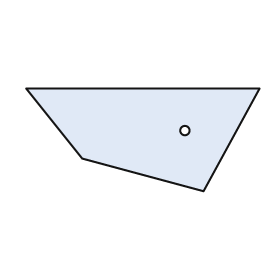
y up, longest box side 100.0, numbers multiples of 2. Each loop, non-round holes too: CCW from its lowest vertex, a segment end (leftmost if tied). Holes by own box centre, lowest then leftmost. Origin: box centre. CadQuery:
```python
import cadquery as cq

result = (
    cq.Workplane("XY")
    .moveTo(26.0, -22.0)
    .lineTo(50.0, 22.0)
    .lineTo(-50.0, 22.0)
    .lineTo(-26.0, -8.0)
    .close()
    .moveTo(18.0, 4.0)
    .circle(2.0)
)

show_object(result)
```